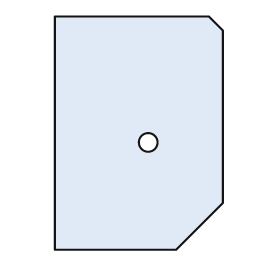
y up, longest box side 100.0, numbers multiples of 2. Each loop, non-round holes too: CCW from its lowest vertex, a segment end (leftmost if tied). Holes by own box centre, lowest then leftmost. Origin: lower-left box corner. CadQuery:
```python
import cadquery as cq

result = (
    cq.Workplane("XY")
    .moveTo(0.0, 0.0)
    .lineTo(52.0, 0.0)
    .lineTo(72.0, 20.0)
    .lineTo(72.0, 94.0)
    .lineTo(66.0, 100.0)
    .lineTo(0.0, 100.0)
    .close()
    .moveTo(40.0, 46.0)
    .circle(4.0)
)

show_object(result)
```